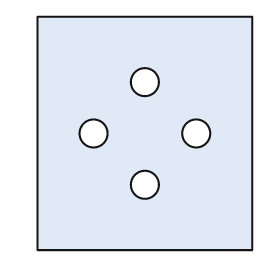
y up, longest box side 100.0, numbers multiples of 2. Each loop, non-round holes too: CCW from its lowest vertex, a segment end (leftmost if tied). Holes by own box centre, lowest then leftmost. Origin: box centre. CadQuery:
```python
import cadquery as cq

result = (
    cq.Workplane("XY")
    .moveTo(-46.0, -50.0)
    .lineTo(46.0, -50.0)
    .lineTo(46.0, 50.0)
    .lineTo(-46.0, 50.0)
    .close()
    .moveTo(0.0, -22.0)
    .circle(6.0)
    .moveTo(-22.0, 0.0)
    .circle(6.0)
    .moveTo(22.0, 0.0)
    .circle(6.0)
    .moveTo(0.0, 22.0)
    .circle(6.0)
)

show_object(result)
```